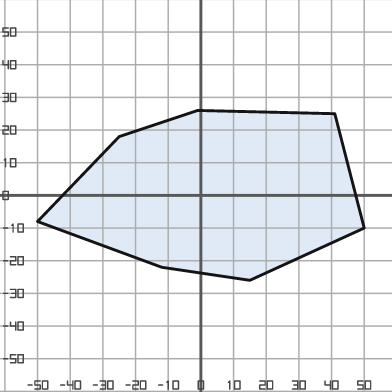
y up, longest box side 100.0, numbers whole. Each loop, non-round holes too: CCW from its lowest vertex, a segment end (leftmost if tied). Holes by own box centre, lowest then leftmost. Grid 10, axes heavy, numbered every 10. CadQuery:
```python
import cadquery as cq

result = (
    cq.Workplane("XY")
    .moveTo(15.0, -26.0)
    .lineTo(50.0, -10.0)
    .lineTo(41.0, 25.0)
    .lineTo(-1.0, 26.0)
    .lineTo(-25.0, 18.0)
    .lineTo(-50.0, -8.0)
    .lineTo(-12.0, -22.0)
    .close()
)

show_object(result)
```